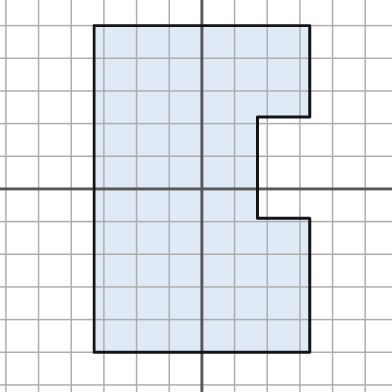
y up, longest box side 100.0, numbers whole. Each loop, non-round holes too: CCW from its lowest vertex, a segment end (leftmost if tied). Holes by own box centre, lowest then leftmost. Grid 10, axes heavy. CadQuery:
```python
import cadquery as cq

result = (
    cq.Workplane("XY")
    .moveTo(-33.0, -50.0)
    .lineTo(33.0, -50.0)
    .lineTo(33.0, -9.0)
    .lineTo(17.0, -9.0)
    .lineTo(17.0, 22.0)
    .lineTo(33.0, 22.0)
    .lineTo(33.0, 50.0)
    .lineTo(-33.0, 50.0)
    .close()
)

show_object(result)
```